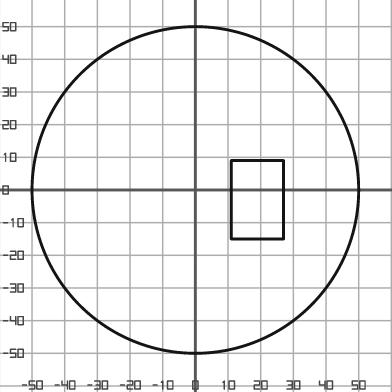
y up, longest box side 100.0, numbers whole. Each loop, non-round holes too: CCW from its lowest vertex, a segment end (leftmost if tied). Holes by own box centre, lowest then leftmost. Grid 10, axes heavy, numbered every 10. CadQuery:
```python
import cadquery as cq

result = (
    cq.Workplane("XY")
    .moveTo(0.0, 0.0)
    .circle(50.0)
    .moveTo(11.0, -15.0)
    .lineTo(27.0, -15.0)
    .lineTo(27.0, 9.0)
    .lineTo(11.0, 9.0)
    .close()
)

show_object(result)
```